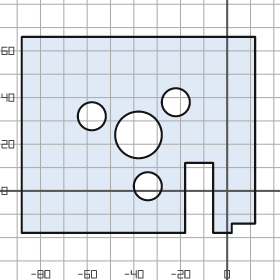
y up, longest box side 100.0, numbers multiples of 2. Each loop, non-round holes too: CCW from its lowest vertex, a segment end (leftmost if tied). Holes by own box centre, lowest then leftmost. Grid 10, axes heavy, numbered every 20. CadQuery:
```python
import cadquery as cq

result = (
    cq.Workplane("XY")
    .moveTo(-88.0, -18.0)
    .lineTo(-18.0, -18.0)
    .lineTo(-18.0, 12.0)
    .lineTo(-6.0, 12.0)
    .lineTo(-6.0, -18.0)
    .lineTo(2.0, -18.0)
    .lineTo(2.0, -14.0)
    .lineTo(12.0, -14.0)
    .lineTo(12.0, 66.0)
    .lineTo(-88.0, 66.0)
    .close()
    .moveTo(-34.0, 2.0)
    .circle(6.0)
    .moveTo(-38.0, 24.0)
    .circle(10.0)
    .moveTo(-58.0, 32.0)
    .circle(6.0)
    .moveTo(-22.0, 38.0)
    .circle(6.0)
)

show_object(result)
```